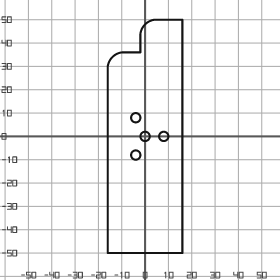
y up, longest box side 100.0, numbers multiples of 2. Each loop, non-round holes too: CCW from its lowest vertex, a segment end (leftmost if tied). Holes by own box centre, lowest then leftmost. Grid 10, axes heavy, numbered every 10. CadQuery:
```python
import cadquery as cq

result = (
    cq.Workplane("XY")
    .moveTo(-16.0, -50.0)
    .lineTo(16.0, -50.0)
    .lineTo(16.0, 50.0)
    .lineTo(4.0, 50.0)
    .threePointArc((0.0, 48.0), (-2.0, 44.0))
    .lineTo(-2.0, 36.0)
    .lineTo(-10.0, 36.0)
    .threePointArc((-14.0, 34.0), (-16.0, 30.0))
    .close()
    .moveTo(-4.0, -8.0)
    .circle(2.0)
    .moveTo(0.0, 0.0)
    .circle(2.0)
    .moveTo(8.0, 0.0)
    .circle(2.0)
    .moveTo(-4.0, 8.0)
    .circle(2.0)
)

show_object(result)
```